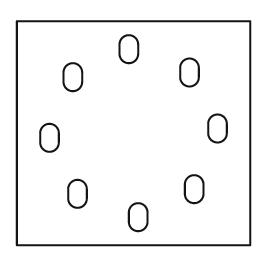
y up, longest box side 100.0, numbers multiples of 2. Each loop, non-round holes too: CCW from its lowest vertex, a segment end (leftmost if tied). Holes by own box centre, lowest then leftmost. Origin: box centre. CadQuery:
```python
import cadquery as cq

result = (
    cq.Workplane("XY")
    .moveTo(-50.0, -48.0)
    .lineTo(50.0, -48.0)
    .lineTo(50.0, 48.0)
    .lineTo(-50.0, 48.0)
    .close()
    .moveTo(-2.0, -38.0)
    .threePointArc((2.0, -42.0), (6.0, -38.0))
    .lineTo(6.0, -34.0)
    .threePointArc((2.0, -30.0), (-2.0, -34.0))
    .close()
    .moveTo(-28.0, -28.0)
    .threePointArc((-24.0, -32.0), (-20.0, -28.0))
    .lineTo(-20.0, -24.0)
    .threePointArc((-24.0, -20.0), (-28.0, -24.0))
    .close()
    .moveTo(22.0, -26.0)
    .threePointArc((26.0, -30.0), (30.0, -26.0))
    .lineTo(30.0, -22.0)
    .threePointArc((26.0, -18.0), (22.0, -22.0))
    .close()
    .moveTo(-40.0, -4.0)
    .threePointArc((-36.0, -8.0), (-32.0, -4.0))
    .lineTo(-32.0, 0.0)
    .threePointArc((-36.0, 4.0), (-40.0, 0.0))
    .close()
    .moveTo(32.0, 0.0)
    .threePointArc((36.0, -4.0), (40.0, 0.0))
    .lineTo(40.0, 4.0)
    .threePointArc((36.0, 8.0), (32.0, 4.0))
    .close()
    .moveTo(-30.0, 22.0)
    .threePointArc((-26.0, 18.0), (-22.0, 22.0))
    .lineTo(-22.0, 26.0)
    .threePointArc((-26.0, 30.0), (-30.0, 26.0))
    .close()
    .moveTo(20.0, 24.0)
    .threePointArc((24.0, 20.0), (28.0, 24.0))
    .lineTo(28.0, 28.0)
    .threePointArc((24.0, 32.0), (20.0, 28.0))
    .close()
    .moveTo(-6.0, 34.0)
    .threePointArc((-2.0, 30.0), (2.0, 34.0))
    .lineTo(2.0, 38.0)
    .threePointArc((-2.0, 42.0), (-6.0, 38.0))
    .close()
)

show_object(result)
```